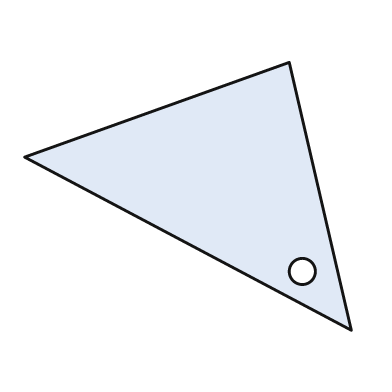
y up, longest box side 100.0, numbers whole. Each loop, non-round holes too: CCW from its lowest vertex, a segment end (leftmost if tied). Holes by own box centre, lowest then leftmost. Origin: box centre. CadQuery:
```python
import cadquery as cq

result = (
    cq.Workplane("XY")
    .moveTo(50.0, -41.0)
    .lineTo(31.0, 41.0)
    .lineTo(-50.0, 12.0)
    .close()
    .moveTo(35.0, -23.0)
    .circle(4.0)
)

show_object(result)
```